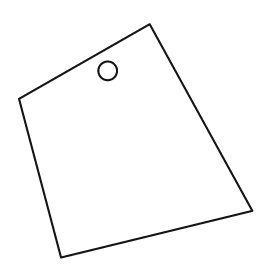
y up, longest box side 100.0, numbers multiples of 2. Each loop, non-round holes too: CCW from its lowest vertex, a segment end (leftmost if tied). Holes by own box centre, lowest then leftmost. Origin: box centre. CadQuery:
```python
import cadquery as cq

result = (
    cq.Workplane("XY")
    .moveTo(-32.0, -50.0)
    .lineTo(50.0, -30.0)
    .lineTo(6.0, 50.0)
    .lineTo(-50.0, 18.0)
    .close()
    .moveTo(-12.0, 30.0)
    .circle(4.0)
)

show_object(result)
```